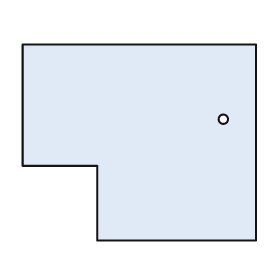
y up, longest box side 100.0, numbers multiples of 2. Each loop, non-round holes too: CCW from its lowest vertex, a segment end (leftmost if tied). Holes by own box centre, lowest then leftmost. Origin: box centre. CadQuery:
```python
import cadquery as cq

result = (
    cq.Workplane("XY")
    .moveTo(-18.0, -42.0)
    .lineTo(50.0, -42.0)
    .lineTo(50.0, 42.0)
    .lineTo(-50.0, 42.0)
    .lineTo(-50.0, -10.0)
    .lineTo(-18.0, -10.0)
    .close()
    .moveTo(36.0, 10.0)
    .circle(2.0)
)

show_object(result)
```